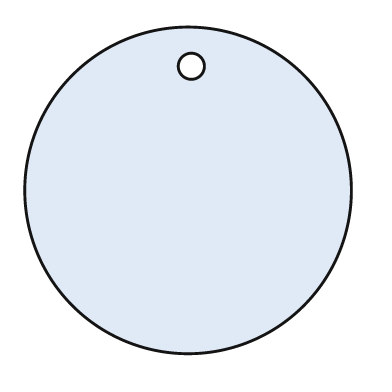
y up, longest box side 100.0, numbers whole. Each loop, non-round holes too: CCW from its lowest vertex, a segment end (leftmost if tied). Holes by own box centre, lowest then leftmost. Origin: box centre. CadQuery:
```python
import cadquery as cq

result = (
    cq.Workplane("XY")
    .moveTo(0.0, 0.0)
    .circle(50.0)
    .moveTo(1.0, 38.0)
    .circle(4.0)
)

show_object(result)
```